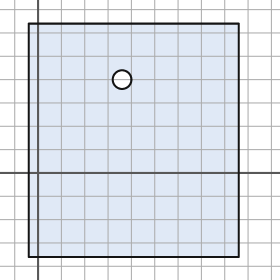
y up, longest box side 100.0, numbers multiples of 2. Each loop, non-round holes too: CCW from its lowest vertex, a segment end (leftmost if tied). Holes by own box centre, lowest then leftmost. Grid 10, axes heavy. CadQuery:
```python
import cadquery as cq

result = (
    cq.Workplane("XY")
    .moveTo(-4.0, -36.0)
    .lineTo(86.0, -36.0)
    .lineTo(86.0, 64.0)
    .lineTo(-4.0, 64.0)
    .close()
    .moveTo(36.0, 40.0)
    .circle(4.0)
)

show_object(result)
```